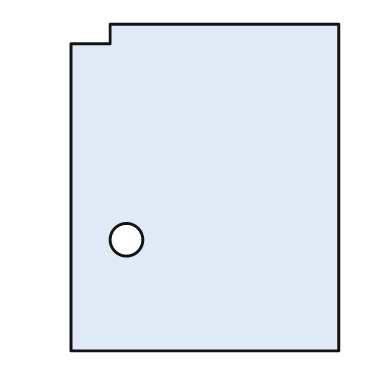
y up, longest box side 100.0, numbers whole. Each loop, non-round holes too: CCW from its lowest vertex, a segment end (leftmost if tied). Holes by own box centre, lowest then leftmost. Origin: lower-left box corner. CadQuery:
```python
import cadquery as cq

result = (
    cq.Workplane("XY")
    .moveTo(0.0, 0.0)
    .lineTo(82.0, 0.0)
    .lineTo(82.0, 100.0)
    .lineTo(12.0, 100.0)
    .lineTo(12.0, 94.0)
    .lineTo(0.0, 94.0)
    .close()
    .moveTo(17.0, 34.0)
    .circle(5.0)
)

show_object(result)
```